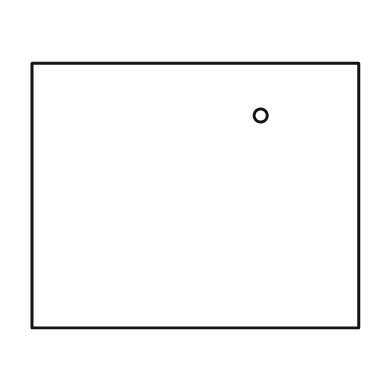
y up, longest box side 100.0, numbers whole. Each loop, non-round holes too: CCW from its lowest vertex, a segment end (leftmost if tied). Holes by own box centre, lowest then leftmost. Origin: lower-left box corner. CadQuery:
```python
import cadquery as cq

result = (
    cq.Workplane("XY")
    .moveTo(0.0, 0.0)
    .lineTo(100.0, 0.0)
    .lineTo(100.0, 81.0)
    .lineTo(0.0, 81.0)
    .close()
    .moveTo(70.0, 65.0)
    .circle(2.0)
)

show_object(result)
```